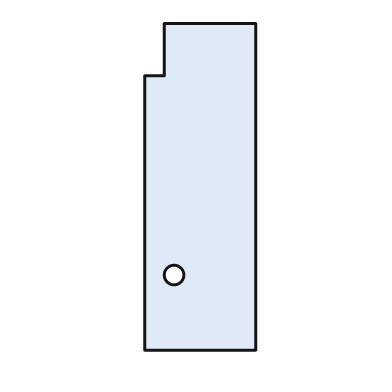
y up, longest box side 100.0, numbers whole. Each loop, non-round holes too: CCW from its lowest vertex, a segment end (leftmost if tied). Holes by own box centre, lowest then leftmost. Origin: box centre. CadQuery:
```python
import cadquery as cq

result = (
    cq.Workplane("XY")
    .moveTo(-17.0, -50.0)
    .lineTo(17.0, -50.0)
    .lineTo(17.0, 50.0)
    .lineTo(-11.0, 50.0)
    .lineTo(-11.0, 34.0)
    .lineTo(-17.0, 34.0)
    .close()
    .moveTo(-8.0, -27.0)
    .circle(3.0)
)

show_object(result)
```